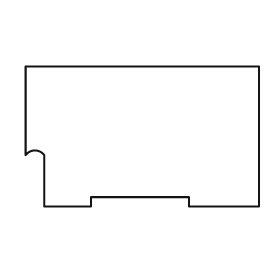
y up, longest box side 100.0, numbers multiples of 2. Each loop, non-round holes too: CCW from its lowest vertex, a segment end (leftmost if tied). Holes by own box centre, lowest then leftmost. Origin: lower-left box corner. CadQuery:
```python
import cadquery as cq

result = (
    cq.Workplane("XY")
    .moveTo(8.0, 0.0)
    .lineTo(28.0, 0.0)
    .lineTo(28.0, 4.0)
    .lineTo(70.0, 4.0)
    .lineTo(70.0, 0.0)
    .lineTo(100.0, 0.0)
    .lineTo(100.0, 60.0)
    .lineTo(0.0, 60.0)
    .lineTo(0.0, 22.0)
    .threePointArc((4.0, 24.0), (8.0, 22.0))
    .close()
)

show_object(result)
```